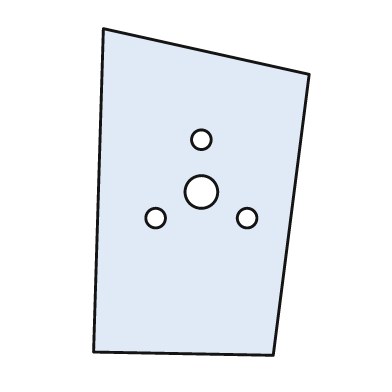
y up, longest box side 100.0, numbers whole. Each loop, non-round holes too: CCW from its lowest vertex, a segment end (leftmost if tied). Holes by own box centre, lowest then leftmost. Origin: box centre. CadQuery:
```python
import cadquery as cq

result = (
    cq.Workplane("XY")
    .moveTo(22.0, -50.0)
    .lineTo(33.0, 36.0)
    .lineTo(-30.0, 50.0)
    .lineTo(-33.0, -49.0)
    .close()
    .moveTo(-14.0, -8.0)
    .circle(3.0)
    .moveTo(14.0, -8.0)
    .circle(3.0)
    .moveTo(0.0, 0.0)
    .circle(5.0)
    .moveTo(0.0, 16.0)
    .circle(3.0)
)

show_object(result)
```